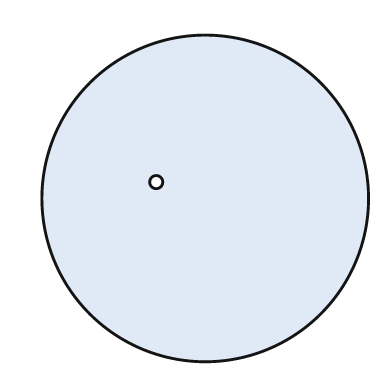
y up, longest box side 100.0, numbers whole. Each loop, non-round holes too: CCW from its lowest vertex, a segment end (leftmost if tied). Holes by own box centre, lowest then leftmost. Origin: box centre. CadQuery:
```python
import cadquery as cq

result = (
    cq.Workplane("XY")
    .moveTo(0.0, 0.0)
    .circle(50.0)
    .moveTo(-15.0, 5.0)
    .circle(2.0)
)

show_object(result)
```